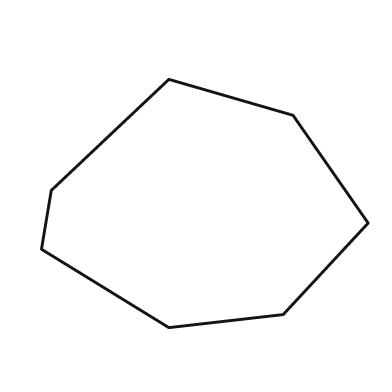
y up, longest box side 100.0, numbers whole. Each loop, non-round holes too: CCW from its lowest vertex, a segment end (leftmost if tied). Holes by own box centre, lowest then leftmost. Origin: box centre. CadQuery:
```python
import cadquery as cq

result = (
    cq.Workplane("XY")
    .moveTo(-11.0, -38.0)
    .lineTo(24.0, -34.0)
    .lineTo(50.0, -6.0)
    .lineTo(27.0, 27.0)
    .lineTo(-11.0, 38.0)
    .lineTo(-47.0, 4.0)
    .lineTo(-50.0, -14.0)
    .close()
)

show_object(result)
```